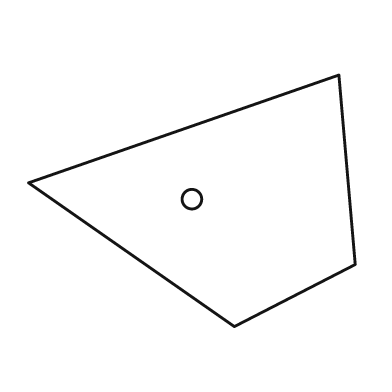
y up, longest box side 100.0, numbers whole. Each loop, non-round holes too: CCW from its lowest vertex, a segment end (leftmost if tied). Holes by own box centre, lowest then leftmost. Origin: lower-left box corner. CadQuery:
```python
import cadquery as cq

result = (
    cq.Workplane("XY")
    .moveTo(63.0, 0.0)
    .lineTo(100.0, 19.0)
    .lineTo(95.0, 77.0)
    .lineTo(0.0, 44.0)
    .close()
    .moveTo(50.0, 39.0)
    .circle(3.0)
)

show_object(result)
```